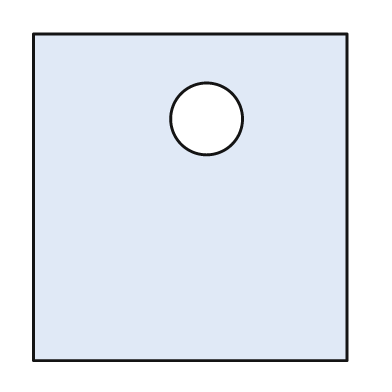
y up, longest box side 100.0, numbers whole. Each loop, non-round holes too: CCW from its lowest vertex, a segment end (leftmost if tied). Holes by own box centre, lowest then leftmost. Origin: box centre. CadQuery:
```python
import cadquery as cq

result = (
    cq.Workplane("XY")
    .moveTo(-48.0, -50.0)
    .lineTo(48.0, -50.0)
    .lineTo(48.0, 50.0)
    .lineTo(-48.0, 50.0)
    .close()
    .moveTo(5.0, 24.0)
    .circle(11.0)
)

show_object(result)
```